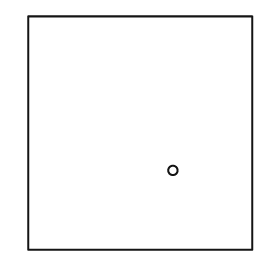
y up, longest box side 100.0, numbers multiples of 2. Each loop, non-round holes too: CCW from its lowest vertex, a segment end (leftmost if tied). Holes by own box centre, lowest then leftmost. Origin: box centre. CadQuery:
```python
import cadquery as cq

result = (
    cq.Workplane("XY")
    .moveTo(-48.0, -50.0)
    .lineTo(48.0, -50.0)
    .lineTo(48.0, 50.0)
    .lineTo(-48.0, 50.0)
    .close()
    .moveTo(14.0, -16.0)
    .circle(2.0)
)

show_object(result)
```